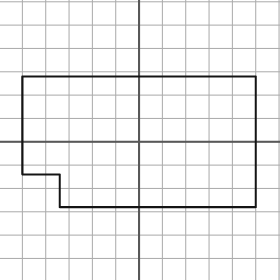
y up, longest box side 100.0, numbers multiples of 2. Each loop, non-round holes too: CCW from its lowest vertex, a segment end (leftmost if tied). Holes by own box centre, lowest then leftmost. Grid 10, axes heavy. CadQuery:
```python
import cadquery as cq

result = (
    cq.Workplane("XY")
    .moveTo(-34.0, -28.0)
    .lineTo(50.0, -28.0)
    .lineTo(50.0, 28.0)
    .lineTo(-50.0, 28.0)
    .lineTo(-50.0, -14.0)
    .lineTo(-34.0, -14.0)
    .close()
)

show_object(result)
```